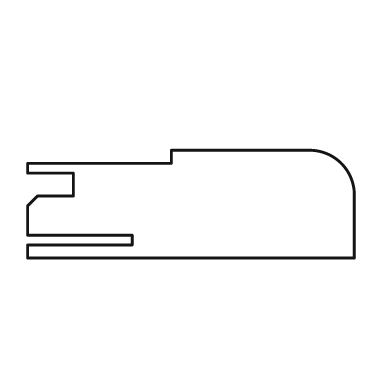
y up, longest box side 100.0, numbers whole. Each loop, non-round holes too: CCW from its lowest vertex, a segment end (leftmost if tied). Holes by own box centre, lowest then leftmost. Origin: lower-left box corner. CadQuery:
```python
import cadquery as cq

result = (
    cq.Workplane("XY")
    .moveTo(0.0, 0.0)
    .lineTo(100.0, 0.0)
    .lineTo(100.0, 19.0)
    .threePointArc((96.0, 29.0), (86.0, 33.0))
    .lineTo(44.0, 33.0)
    .lineTo(44.0, 29.0)
    .lineTo(0.0, 29.0)
    .lineTo(0.0, 26.0)
    .lineTo(14.0, 26.0)
    .lineTo(14.0, 19.0)
    .lineTo(3.0, 19.0)
    .lineTo(0.0, 16.0)
    .lineTo(0.0, 7.0)
    .lineTo(32.0, 7.0)
    .lineTo(32.0, 4.0)
    .lineTo(0.0, 4.0)
    .close()
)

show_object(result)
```